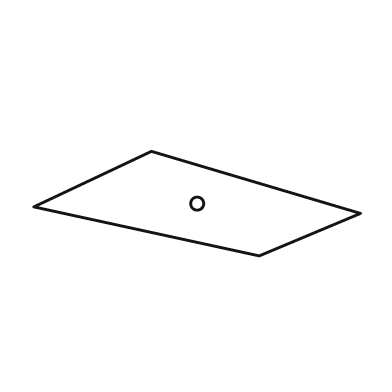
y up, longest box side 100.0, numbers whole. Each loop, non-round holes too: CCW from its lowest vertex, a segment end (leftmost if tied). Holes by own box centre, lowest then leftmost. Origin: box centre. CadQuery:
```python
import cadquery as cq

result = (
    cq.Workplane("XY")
    .moveTo(19.0, -16.0)
    .lineTo(50.0, -3.0)
    .lineTo(-14.0, 16.0)
    .lineTo(-50.0, -1.0)
    .close()
    .moveTo(0.0, 0.0)
    .circle(2.0)
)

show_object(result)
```